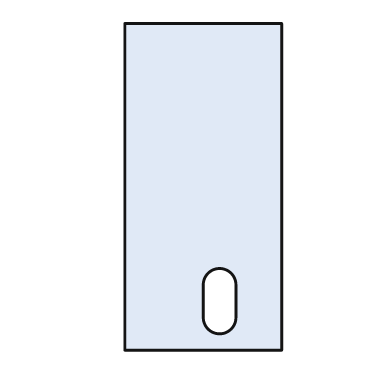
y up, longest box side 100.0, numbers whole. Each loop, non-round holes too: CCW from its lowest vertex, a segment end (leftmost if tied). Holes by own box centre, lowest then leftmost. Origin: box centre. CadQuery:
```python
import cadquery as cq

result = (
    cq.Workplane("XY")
    .moveTo(-24.0, -50.0)
    .lineTo(24.0, -50.0)
    .lineTo(24.0, 50.0)
    .lineTo(-24.0, 50.0)
    .close()
    .moveTo(0.0, -40.0)
    .threePointArc((5.0, -45.0), (10.0, -40.0))
    .lineTo(10.0, -30.0)
    .threePointArc((5.0, -25.0), (0.0, -30.0))
    .close()
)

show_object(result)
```